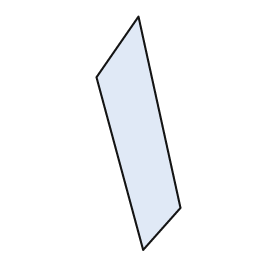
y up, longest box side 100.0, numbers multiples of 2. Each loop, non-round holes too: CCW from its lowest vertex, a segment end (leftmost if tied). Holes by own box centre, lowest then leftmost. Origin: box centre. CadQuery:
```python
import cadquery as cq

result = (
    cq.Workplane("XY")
    .moveTo(2.0, -50.0)
    .lineTo(18.0, -32.0)
    .lineTo(0.0, 50.0)
    .lineTo(-18.0, 24.0)
    .close()
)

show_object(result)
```